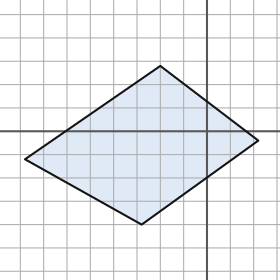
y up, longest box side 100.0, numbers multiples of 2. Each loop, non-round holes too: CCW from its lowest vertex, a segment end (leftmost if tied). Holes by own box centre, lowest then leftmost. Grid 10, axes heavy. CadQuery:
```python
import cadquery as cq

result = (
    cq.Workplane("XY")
    .moveTo(-28.0, -40.0)
    .lineTo(22.0, -4.0)
    .lineTo(-20.0, 28.0)
    .lineTo(-78.0, -12.0)
    .close()
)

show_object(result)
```